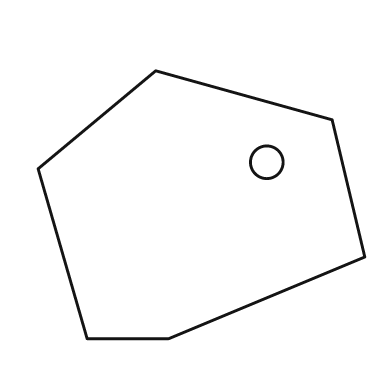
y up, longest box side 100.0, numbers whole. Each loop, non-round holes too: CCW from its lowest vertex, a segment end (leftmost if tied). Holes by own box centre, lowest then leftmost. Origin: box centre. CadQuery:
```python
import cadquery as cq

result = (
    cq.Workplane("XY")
    .moveTo(-35.0, -41.0)
    .lineTo(-10.0, -41.0)
    .lineTo(50.0, -16.0)
    .lineTo(40.0, 26.0)
    .lineTo(-14.0, 41.0)
    .lineTo(-50.0, 11.0)
    .close()
    .moveTo(20.0, 13.0)
    .circle(5.0)
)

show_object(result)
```